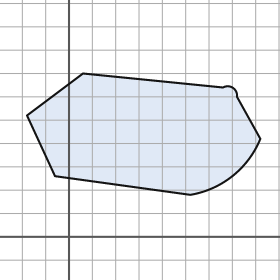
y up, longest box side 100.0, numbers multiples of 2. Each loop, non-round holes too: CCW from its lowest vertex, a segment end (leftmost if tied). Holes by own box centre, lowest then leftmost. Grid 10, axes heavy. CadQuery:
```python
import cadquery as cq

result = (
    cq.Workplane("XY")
    .moveTo(52.0, 18.0)
    .threePointArc((70.0, 26.0), (82.0, 42.0))
    .lineTo(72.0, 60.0)
    .threePointArc((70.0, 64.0), (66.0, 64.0))
    .lineTo(6.0, 70.0)
    .lineTo(-18.0, 52.0)
    .lineTo(-6.0, 26.0)
    .close()
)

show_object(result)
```